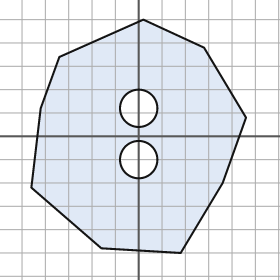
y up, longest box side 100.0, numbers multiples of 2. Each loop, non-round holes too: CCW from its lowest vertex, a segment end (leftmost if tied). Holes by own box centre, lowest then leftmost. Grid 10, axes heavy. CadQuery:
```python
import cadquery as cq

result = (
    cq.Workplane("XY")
    .moveTo(18.0, -50.0)
    .lineTo(36.0, -20.0)
    .lineTo(46.0, 8.0)
    .lineTo(28.0, 38.0)
    .lineTo(2.0, 50.0)
    .lineTo(-34.0, 34.0)
    .lineTo(-42.0, 12.0)
    .lineTo(-46.0, -22.0)
    .lineTo(-16.0, -48.0)
    .close()
    .moveTo(0.0, -10.0)
    .circle(8.0)
    .moveTo(0.0, 12.0)
    .circle(8.0)
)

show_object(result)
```